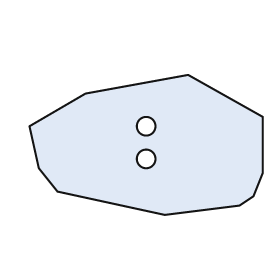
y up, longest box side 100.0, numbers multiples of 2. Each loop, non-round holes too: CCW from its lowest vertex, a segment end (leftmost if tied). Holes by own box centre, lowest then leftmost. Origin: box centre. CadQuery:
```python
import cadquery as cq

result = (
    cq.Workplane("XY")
    .moveTo(8.0, -30.0)
    .lineTo(40.0, -26.0)
    .lineTo(46.0, -22.0)
    .lineTo(50.0, -12.0)
    .lineTo(50.0, 12.0)
    .lineTo(18.0, 30.0)
    .lineTo(-26.0, 22.0)
    .lineTo(-50.0, 8.0)
    .lineTo(-46.0, -10.0)
    .lineTo(-38.0, -20.0)
    .close()
    .moveTo(0.0, -6.0)
    .circle(4.0)
    .moveTo(0.0, 8.0)
    .circle(4.0)
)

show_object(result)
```